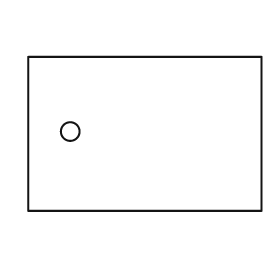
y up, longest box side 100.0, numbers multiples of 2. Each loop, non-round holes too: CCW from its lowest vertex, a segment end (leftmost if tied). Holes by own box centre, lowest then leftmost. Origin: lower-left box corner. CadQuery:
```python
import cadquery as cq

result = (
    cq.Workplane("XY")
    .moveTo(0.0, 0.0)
    .lineTo(100.0, 0.0)
    .lineTo(100.0, 66.0)
    .lineTo(0.0, 66.0)
    .close()
    .moveTo(18.0, 34.0)
    .circle(4.0)
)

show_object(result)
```